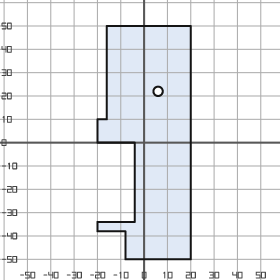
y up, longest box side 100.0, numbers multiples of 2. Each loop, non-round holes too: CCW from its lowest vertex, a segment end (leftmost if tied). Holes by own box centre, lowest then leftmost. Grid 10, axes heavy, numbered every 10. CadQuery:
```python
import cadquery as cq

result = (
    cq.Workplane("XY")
    .moveTo(-8.0, -50.0)
    .lineTo(20.0, -50.0)
    .lineTo(20.0, 50.0)
    .lineTo(-16.0, 50.0)
    .lineTo(-16.0, 10.0)
    .lineTo(-20.0, 10.0)
    .lineTo(-20.0, 0.0)
    .lineTo(-4.0, 0.0)
    .lineTo(-4.0, -34.0)
    .lineTo(-20.0, -34.0)
    .lineTo(-20.0, -38.0)
    .lineTo(-8.0, -38.0)
    .close()
    .moveTo(6.0, 22.0)
    .circle(2.0)
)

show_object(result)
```